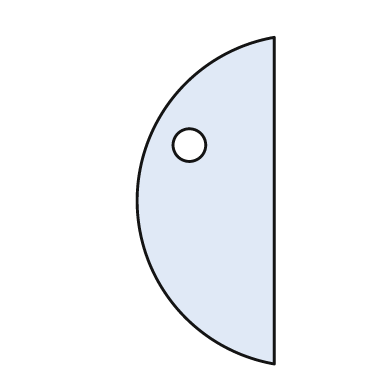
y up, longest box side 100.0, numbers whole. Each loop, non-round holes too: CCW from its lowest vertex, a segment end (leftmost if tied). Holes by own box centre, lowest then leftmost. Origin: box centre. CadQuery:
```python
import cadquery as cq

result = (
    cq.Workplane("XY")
    .moveTo(21.0, -50.0)
    .lineTo(21.0, 50.0)
    .threePointArc((-21.0, 0.0), (21.0, -50.0))
    .close()
    .moveTo(-5.0, 17.0)
    .circle(5.0)
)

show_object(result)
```